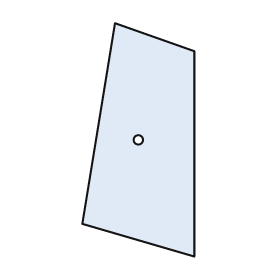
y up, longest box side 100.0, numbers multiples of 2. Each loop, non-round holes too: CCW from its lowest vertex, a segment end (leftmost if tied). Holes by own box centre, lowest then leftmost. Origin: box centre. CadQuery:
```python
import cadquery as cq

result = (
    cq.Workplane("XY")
    .moveTo(24.0, -50.0)
    .lineTo(24.0, 38.0)
    .lineTo(-10.0, 50.0)
    .lineTo(-24.0, -36.0)
    .close()
    .moveTo(0.0, 0.0)
    .circle(2.0)
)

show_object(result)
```